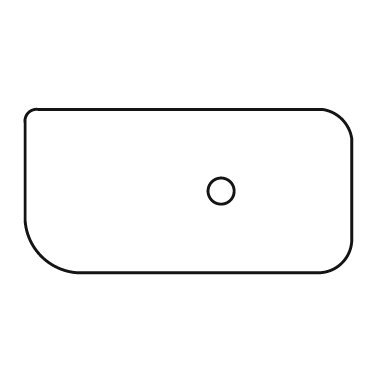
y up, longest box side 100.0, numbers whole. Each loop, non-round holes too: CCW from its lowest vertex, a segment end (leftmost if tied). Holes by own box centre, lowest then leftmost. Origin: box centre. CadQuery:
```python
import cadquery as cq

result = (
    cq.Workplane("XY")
    .moveTo(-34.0, -25.0)
    .lineTo(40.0, -25.0)
    .threePointArc((47.0, -22.0), (50.0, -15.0))
    .lineTo(50.0, 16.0)
    .threePointArc((47.0, 22.0), (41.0, 25.0))
    .lineTo(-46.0, 25.0)
    .threePointArc((-49.0, 24.0), (-50.0, 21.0))
    .lineTo(-50.0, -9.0)
    .threePointArc((-45.0, -20.0), (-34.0, -25.0))
    .close()
    .moveTo(10.0, 0.0)
    .circle(4.0)
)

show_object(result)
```